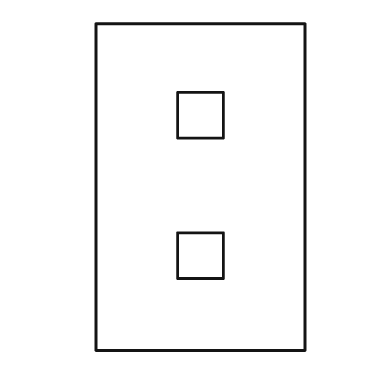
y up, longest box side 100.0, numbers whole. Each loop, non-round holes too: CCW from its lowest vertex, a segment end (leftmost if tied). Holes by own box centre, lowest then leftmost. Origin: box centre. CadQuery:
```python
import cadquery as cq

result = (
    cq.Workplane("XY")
    .moveTo(-32.0, -50.0)
    .lineTo(32.0, -50.0)
    .lineTo(32.0, 50.0)
    .lineTo(-32.0, 50.0)
    .close()
    .moveTo(-7.0, -28.0)
    .lineTo(7.0, -28.0)
    .lineTo(7.0, -14.0)
    .lineTo(-7.0, -14.0)
    .close()
    .moveTo(-7.0, 15.0)
    .lineTo(7.0, 15.0)
    .lineTo(7.0, 29.0)
    .lineTo(-7.0, 29.0)
    .close()
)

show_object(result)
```